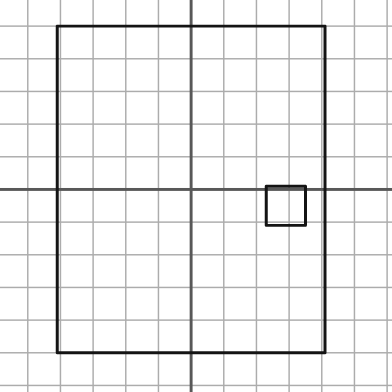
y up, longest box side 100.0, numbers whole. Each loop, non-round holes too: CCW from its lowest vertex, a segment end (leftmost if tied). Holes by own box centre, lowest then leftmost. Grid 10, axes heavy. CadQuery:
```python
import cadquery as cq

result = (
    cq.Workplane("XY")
    .moveTo(-41.0, -50.0)
    .lineTo(41.0, -50.0)
    .lineTo(41.0, 50.0)
    .lineTo(-41.0, 50.0)
    .close()
    .moveTo(23.0, -11.0)
    .lineTo(35.0, -11.0)
    .lineTo(35.0, 1.0)
    .lineTo(23.0, 1.0)
    .close()
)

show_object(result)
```